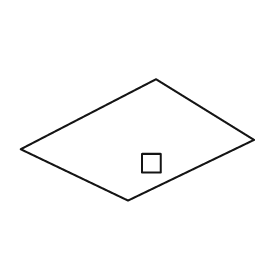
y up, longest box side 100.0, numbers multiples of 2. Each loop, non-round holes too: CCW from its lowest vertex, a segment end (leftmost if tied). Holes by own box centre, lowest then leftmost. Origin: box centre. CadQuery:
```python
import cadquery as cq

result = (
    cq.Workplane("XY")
    .moveTo(-4.0, -26.0)
    .lineTo(50.0, 0.0)
    .lineTo(8.0, 26.0)
    .lineTo(-50.0, -4.0)
    .close()
    .moveTo(2.0, -14.0)
    .lineTo(10.0, -14.0)
    .lineTo(10.0, -6.0)
    .lineTo(2.0, -6.0)
    .close()
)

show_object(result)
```